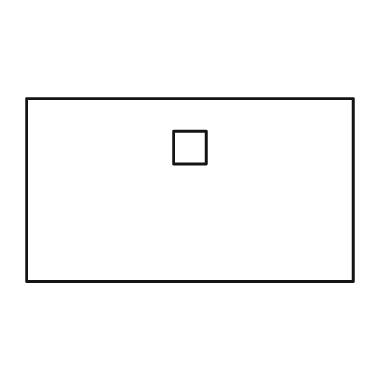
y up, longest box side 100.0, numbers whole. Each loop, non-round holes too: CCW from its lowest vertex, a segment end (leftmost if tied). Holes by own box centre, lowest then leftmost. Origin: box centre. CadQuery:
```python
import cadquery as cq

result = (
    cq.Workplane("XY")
    .moveTo(-50.0, -28.0)
    .lineTo(50.0, -28.0)
    .lineTo(50.0, 28.0)
    .lineTo(-50.0, 28.0)
    .close()
    .moveTo(-5.0, 8.0)
    .lineTo(5.0, 8.0)
    .lineTo(5.0, 18.0)
    .lineTo(-5.0, 18.0)
    .close()
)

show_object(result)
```